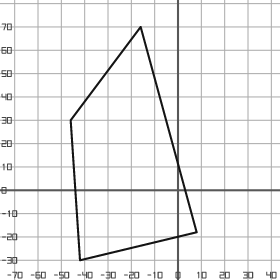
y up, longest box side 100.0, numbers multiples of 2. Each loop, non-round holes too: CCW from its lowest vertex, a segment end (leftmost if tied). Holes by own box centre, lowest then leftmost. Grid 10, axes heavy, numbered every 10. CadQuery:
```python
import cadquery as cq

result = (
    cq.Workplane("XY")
    .moveTo(-42.0, -30.0)
    .lineTo(8.0, -18.0)
    .lineTo(-16.0, 70.0)
    .lineTo(-46.0, 30.0)
    .close()
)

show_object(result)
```